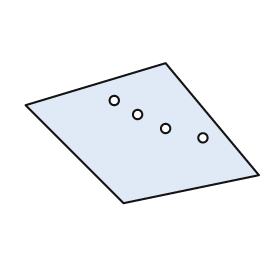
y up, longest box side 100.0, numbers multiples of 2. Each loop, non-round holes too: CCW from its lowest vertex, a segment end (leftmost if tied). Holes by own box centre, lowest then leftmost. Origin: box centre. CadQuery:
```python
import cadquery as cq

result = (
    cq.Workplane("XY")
    .moveTo(-8.0, -30.0)
    .lineTo(50.0, -18.0)
    .lineTo(10.0, 30.0)
    .lineTo(-50.0, 12.0)
    .close()
    .moveTo(26.0, -2.0)
    .circle(2.0)
    .moveTo(10.0, 2.0)
    .circle(2.0)
    .moveTo(-2.0, 8.0)
    .circle(2.0)
    .moveTo(-12.0, 14.0)
    .circle(2.0)
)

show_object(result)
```